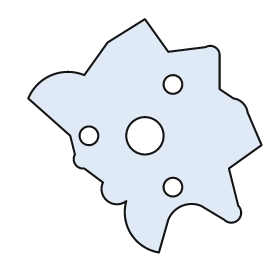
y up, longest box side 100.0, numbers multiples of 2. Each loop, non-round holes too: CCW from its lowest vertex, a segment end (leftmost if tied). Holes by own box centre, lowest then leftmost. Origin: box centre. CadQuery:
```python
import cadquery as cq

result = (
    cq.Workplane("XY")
    .moveTo(6.0, -50.0)
    .lineTo(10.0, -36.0)
    .threePointArc((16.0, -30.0), (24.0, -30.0))
    .lineTo(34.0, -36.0)
    .threePointArc((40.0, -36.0), (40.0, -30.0))
    .lineTo(36.0, -14.0)
    .lineTo(50.0, -4.0)
    .lineTo(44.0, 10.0)
    .threePointArc((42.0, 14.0), (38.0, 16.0))
    .lineTo(32.0, 20.0)
    .lineTo(32.0, 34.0)
    .threePointArc((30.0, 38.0), (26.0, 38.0))
    .lineTo(10.0, 36.0)
    .lineTo(0.0, 50.0)
    .lineTo(-16.0, 40.0)
    .lineTo(-26.0, 26.0)
    .threePointArc((-40.0, 26.0), (-50.0, 16.0))
    .lineTo(-32.0, 0.0)
    .lineTo(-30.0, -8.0)
    .threePointArc((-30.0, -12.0), (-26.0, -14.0))
    .lineTo(-18.0, -20.0)
    .threePointArc((-16.0, -28.0), (-8.0, -28.0))
    .threePointArc((-6.0, -42.0), (6.0, -50.0))
    .close()
    .moveTo(12.0, -22.0)
    .circle(4.0)
    .moveTo(-24.0, 0.0)
    .circle(4.0)
    .moveTo(0.0, 0.0)
    .circle(8.0)
    .moveTo(12.0, 22.0)
    .circle(4.0)
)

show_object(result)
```